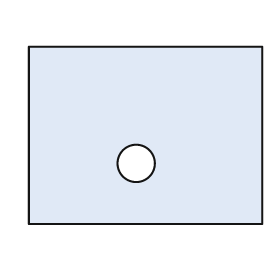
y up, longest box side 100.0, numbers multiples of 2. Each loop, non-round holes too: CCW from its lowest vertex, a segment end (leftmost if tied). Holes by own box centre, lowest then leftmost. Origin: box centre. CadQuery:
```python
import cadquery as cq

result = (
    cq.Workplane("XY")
    .moveTo(-50.0, -38.0)
    .lineTo(50.0, -38.0)
    .lineTo(50.0, 38.0)
    .lineTo(-50.0, 38.0)
    .close()
    .moveTo(-4.0, -12.0)
    .circle(8.0)
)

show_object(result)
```